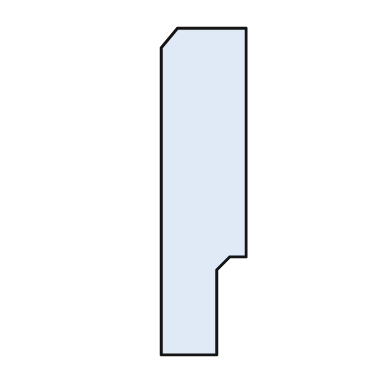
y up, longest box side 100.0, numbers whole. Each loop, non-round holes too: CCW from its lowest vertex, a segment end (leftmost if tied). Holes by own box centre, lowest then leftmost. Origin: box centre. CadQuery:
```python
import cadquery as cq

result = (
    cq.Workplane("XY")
    .moveTo(-13.0, -50.0)
    .lineTo(4.0, -50.0)
    .lineTo(4.0, -24.0)
    .lineTo(8.0, -20.0)
    .lineTo(13.0, -20.0)
    .lineTo(13.0, 50.0)
    .lineTo(-8.0, 50.0)
    .lineTo(-13.0, 44.0)
    .close()
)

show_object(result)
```